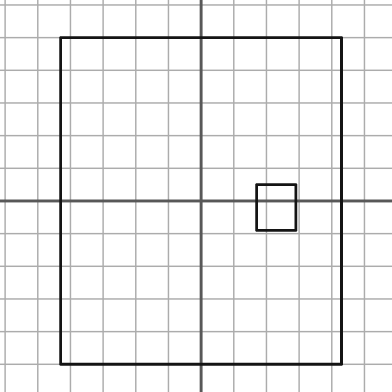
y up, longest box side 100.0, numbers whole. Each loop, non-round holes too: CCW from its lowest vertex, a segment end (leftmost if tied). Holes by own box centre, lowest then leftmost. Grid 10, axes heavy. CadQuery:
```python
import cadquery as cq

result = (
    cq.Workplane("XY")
    .moveTo(-43.0, -50.0)
    .lineTo(43.0, -50.0)
    .lineTo(43.0, 50.0)
    .lineTo(-43.0, 50.0)
    .close()
    .moveTo(17.0, -9.0)
    .lineTo(29.0, -9.0)
    .lineTo(29.0, 5.0)
    .lineTo(17.0, 5.0)
    .close()
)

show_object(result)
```